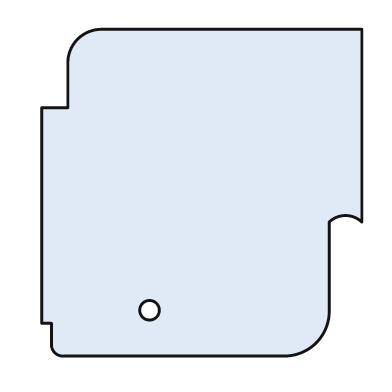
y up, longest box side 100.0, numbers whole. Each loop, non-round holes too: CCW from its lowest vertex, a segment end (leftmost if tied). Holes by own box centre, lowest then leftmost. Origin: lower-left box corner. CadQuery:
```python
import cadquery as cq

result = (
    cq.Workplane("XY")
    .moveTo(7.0, 0.0)
    .lineTo(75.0, 0.0)
    .threePointArc((84.0, 4.0), (88.0, 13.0))
    .lineTo(88.0, 41.0)
    .threePointArc((93.0, 43.0), (98.0, 41.0))
    .lineTo(98.0, 100.0)
    .lineTo(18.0, 100.0)
    .threePointArc((11.0, 97.0), (8.0, 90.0))
    .lineTo(8.0, 76.0)
    .lineTo(0.0, 76.0)
    .lineTo(0.0, 10.0)
    .lineTo(3.0, 10.0)
    .lineTo(3.0, 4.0)
    .threePointArc((4.0, 1.0), (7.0, 0.0))
    .close()
    .moveTo(33.0, 14.0)
    .circle(3.0)
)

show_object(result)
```